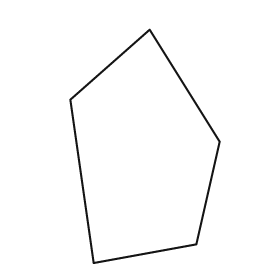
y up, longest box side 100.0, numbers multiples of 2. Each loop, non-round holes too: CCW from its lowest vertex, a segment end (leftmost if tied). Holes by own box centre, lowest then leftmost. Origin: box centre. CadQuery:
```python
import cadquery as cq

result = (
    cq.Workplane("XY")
    .moveTo(-22.0, -50.0)
    .lineTo(22.0, -42.0)
    .lineTo(32.0, 2.0)
    .lineTo(2.0, 50.0)
    .lineTo(-32.0, 20.0)
    .close()
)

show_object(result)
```